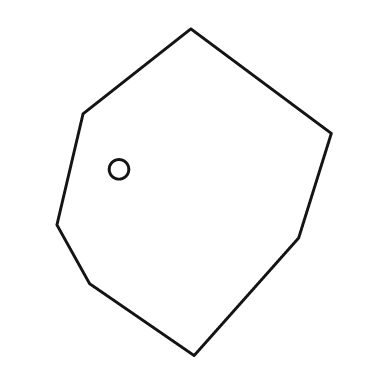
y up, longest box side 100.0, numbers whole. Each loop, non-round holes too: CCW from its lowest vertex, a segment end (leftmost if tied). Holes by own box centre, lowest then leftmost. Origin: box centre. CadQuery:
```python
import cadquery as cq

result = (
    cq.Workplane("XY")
    .moveTo(0.0, -50.0)
    .lineTo(32.0, -14.0)
    .lineTo(42.0, 18.0)
    .lineTo(-1.0, 50.0)
    .lineTo(-34.0, 24.0)
    .lineTo(-42.0, -10.0)
    .lineTo(-32.0, -28.0)
    .close()
    .moveTo(-23.0, 7.0)
    .circle(3.0)
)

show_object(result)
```